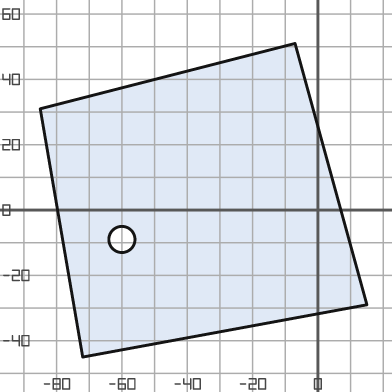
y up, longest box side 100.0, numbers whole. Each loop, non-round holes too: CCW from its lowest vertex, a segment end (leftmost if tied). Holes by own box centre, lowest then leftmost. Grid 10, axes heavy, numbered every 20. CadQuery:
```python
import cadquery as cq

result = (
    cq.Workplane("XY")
    .moveTo(-72.0, -45.0)
    .lineTo(15.0, -29.0)
    .lineTo(-7.0, 51.0)
    .lineTo(-85.0, 31.0)
    .close()
    .moveTo(-60.0, -9.0)
    .circle(4.0)
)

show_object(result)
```